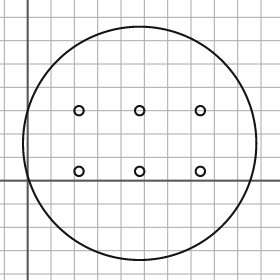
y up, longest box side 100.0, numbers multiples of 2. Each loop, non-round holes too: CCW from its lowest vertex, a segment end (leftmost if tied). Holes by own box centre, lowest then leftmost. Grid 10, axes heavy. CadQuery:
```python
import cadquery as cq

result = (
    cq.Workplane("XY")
    .moveTo(48.0, 16.0)
    .circle(50.0)
    .moveTo(22.0, 4.0)
    .circle(2.0)
    .moveTo(48.0, 4.0)
    .circle(2.0)
    .moveTo(74.0, 4.0)
    .circle(2.0)
    .moveTo(22.0, 30.0)
    .circle(2.0)
    .moveTo(48.0, 30.0)
    .circle(2.0)
    .moveTo(74.0, 30.0)
    .circle(2.0)
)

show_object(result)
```